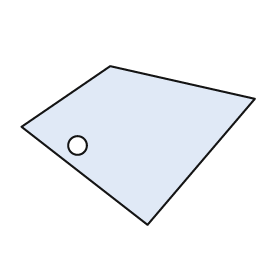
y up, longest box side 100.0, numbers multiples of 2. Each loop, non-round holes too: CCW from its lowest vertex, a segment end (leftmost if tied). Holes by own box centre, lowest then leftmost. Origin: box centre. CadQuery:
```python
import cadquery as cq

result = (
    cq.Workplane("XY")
    .moveTo(4.0, -34.0)
    .lineTo(50.0, 20.0)
    .lineTo(-12.0, 34.0)
    .lineTo(-50.0, 8.0)
    .close()
    .moveTo(-26.0, 0.0)
    .circle(4.0)
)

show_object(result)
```